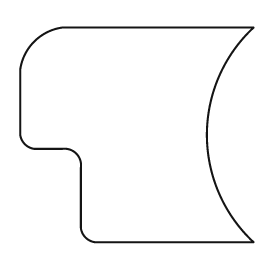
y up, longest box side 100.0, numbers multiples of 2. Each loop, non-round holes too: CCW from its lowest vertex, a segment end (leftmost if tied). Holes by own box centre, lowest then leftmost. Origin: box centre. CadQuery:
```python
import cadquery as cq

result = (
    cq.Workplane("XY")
    .moveTo(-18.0, -46.0)
    .lineTo(50.0, -46.0)
    .threePointArc((30.0, 0.0), (50.0, 46.0))
    .lineTo(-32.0, 46.0)
    .threePointArc((-44.0, 40.0), (-50.0, 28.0))
    .lineTo(-50.0, 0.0)
    .threePointArc((-48.0, -4.0), (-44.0, -6.0))
    .lineTo(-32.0, -6.0)
    .threePointArc((-26.0, -8.0), (-24.0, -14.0))
    .lineTo(-24.0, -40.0)
    .threePointArc((-22.0, -44.0), (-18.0, -46.0))
    .close()
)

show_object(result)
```